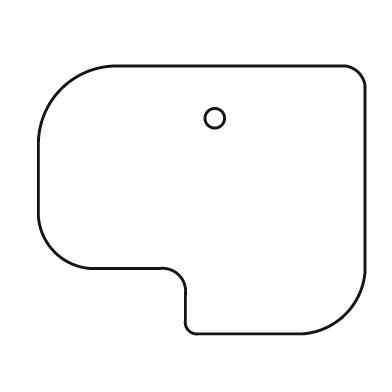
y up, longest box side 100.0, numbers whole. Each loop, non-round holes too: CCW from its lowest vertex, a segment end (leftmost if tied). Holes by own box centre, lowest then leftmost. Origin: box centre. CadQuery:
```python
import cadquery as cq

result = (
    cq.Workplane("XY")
    .moveTo(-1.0, -41.0)
    .lineTo(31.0, -41.0)
    .threePointArc((44.0, -35.0), (50.0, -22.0))
    .lineTo(50.0, 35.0)
    .threePointArc((48.0, 39.0), (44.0, 41.0))
    .lineTo(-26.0, 41.0)
    .threePointArc((-43.0, 34.0), (-50.0, 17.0))
    .lineTo(-50.0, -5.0)
    .threePointArc((-45.0, -16.0), (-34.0, -21.0))
    .lineTo(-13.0, -21.0)
    .threePointArc((-7.0, -23.0), (-5.0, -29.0))
    .lineTo(-5.0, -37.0)
    .threePointArc((-4.0, -40.0), (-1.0, -41.0))
    .close()
    .moveTo(4.0, 25.0)
    .circle(3.0)
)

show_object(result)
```